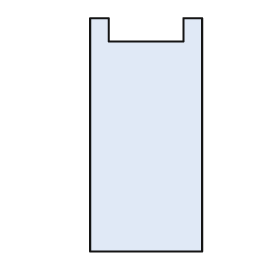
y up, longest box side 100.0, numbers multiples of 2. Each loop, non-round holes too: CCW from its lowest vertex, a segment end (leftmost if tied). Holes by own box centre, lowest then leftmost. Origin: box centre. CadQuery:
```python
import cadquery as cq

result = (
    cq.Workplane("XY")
    .moveTo(-24.0, -50.0)
    .lineTo(24.0, -50.0)
    .lineTo(24.0, 50.0)
    .lineTo(16.0, 50.0)
    .lineTo(16.0, 40.0)
    .lineTo(-16.0, 40.0)
    .lineTo(-16.0, 50.0)
    .lineTo(-24.0, 50.0)
    .close()
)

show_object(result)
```